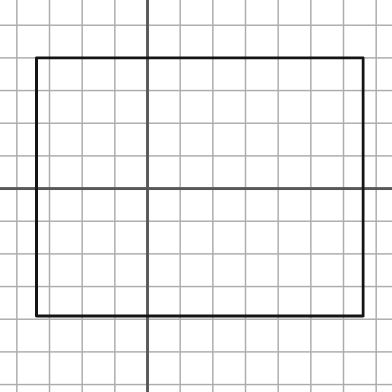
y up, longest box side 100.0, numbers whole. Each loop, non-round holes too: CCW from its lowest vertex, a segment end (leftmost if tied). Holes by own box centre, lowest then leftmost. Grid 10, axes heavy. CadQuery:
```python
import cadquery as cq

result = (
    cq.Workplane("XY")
    .moveTo(-34.0, -39.0)
    .lineTo(66.0, -39.0)
    .lineTo(66.0, 40.0)
    .lineTo(-34.0, 40.0)
    .close()
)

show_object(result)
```